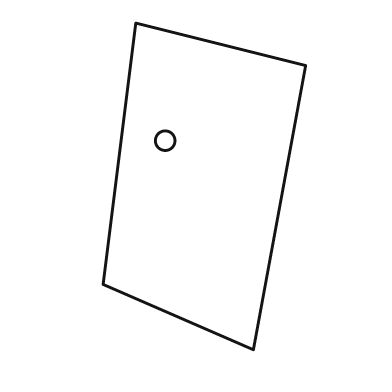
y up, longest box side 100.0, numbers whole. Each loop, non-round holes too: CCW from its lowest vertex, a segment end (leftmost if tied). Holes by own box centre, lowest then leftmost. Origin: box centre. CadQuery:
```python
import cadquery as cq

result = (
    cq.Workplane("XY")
    .moveTo(15.0, -50.0)
    .lineTo(31.0, 37.0)
    .lineTo(-21.0, 50.0)
    .lineTo(-31.0, -30.0)
    .close()
    .moveTo(-12.0, 14.0)
    .circle(3.0)
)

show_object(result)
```